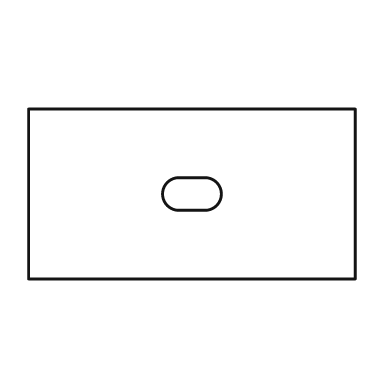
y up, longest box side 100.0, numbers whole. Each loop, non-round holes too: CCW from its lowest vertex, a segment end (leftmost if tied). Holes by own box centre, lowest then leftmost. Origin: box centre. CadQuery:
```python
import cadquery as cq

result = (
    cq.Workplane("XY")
    .moveTo(-50.0, -26.0)
    .lineTo(50.0, -26.0)
    .lineTo(50.0, 26.0)
    .lineTo(-50.0, 26.0)
    .close()
    .moveTo(-4.0, -5.0)
    .lineTo(4.0, -5.0)
    .threePointArc((9.0, 0.0), (4.0, 5.0))
    .lineTo(-4.0, 5.0)
    .threePointArc((-9.0, 0.0), (-4.0, -5.0))
    .close()
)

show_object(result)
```